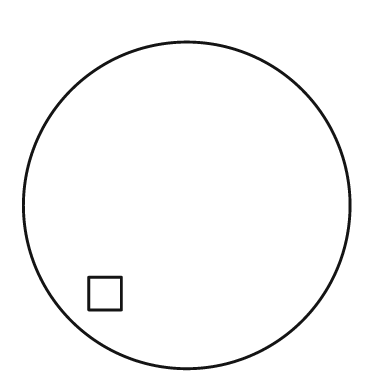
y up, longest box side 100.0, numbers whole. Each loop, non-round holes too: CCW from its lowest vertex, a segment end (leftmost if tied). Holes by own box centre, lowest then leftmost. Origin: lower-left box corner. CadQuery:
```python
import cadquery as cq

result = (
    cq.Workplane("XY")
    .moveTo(50.0, 50.0)
    .circle(50.0)
    .moveTo(20.0, 18.0)
    .lineTo(30.0, 18.0)
    .lineTo(30.0, 28.0)
    .lineTo(20.0, 28.0)
    .close()
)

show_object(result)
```